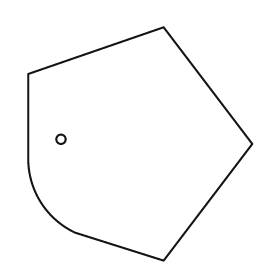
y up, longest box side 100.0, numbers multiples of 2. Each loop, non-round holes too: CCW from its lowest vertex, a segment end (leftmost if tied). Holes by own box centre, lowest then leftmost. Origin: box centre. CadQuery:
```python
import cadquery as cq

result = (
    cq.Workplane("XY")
    .moveTo(10.0, -50.0)
    .lineTo(48.0, 0.0)
    .lineTo(10.0, 50.0)
    .lineTo(-48.0, 30.0)
    .lineTo(-48.0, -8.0)
    .threePointArc((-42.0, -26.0), (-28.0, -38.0))
    .close()
    .moveTo(-34.0, 2.0)
    .circle(2.0)
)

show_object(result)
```